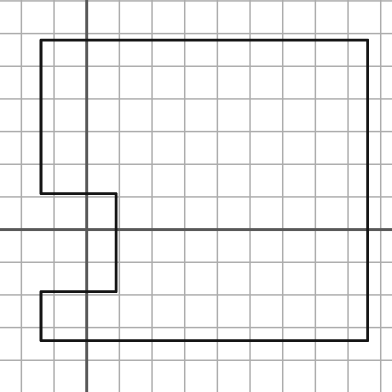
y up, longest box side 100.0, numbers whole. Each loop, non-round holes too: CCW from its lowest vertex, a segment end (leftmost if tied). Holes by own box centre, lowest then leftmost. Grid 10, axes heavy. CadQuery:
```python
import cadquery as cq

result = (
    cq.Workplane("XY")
    .moveTo(-14.0, -34.0)
    .lineTo(86.0, -34.0)
    .lineTo(86.0, 58.0)
    .lineTo(-14.0, 58.0)
    .lineTo(-14.0, 11.0)
    .lineTo(9.0, 11.0)
    .lineTo(9.0, -19.0)
    .lineTo(-14.0, -19.0)
    .close()
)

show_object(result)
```